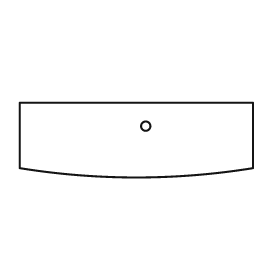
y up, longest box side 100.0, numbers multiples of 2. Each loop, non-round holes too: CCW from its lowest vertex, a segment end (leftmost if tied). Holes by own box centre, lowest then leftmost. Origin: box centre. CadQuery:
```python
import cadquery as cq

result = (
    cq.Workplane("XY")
    .moveTo(-50.0, -12.0)
    .threePointArc((0.0, -16.0), (50.0, -12.0))
    .lineTo(50.0, 16.0)
    .lineTo(-50.0, 16.0)
    .close()
    .moveTo(4.0, 6.0)
    .circle(2.0)
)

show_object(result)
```